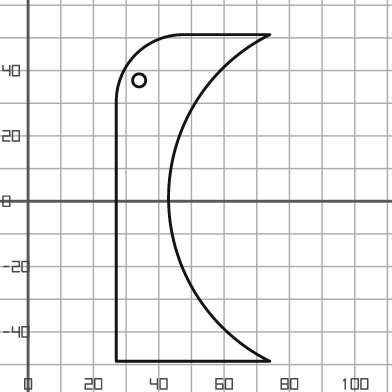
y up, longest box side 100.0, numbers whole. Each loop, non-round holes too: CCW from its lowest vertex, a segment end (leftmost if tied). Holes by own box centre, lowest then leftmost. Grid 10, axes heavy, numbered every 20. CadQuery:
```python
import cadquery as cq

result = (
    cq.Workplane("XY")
    .moveTo(27.0, -49.0)
    .lineTo(74.0, -49.0)
    .threePointArc((43.0, 1.0), (74.0, 51.0))
    .lineTo(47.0, 51.0)
    .threePointArc((33.0, 45.0), (27.0, 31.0))
    .close()
    .moveTo(34.0, 37.0)
    .circle(2.0)
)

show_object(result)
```